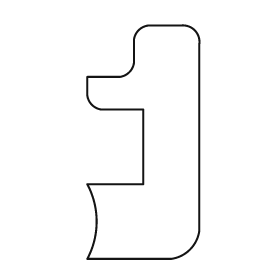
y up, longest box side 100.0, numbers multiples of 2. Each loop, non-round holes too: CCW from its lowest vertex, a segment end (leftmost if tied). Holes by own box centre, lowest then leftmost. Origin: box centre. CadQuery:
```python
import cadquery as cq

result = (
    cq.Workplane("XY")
    .moveTo(-24.0, -50.0)
    .lineTo(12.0, -50.0)
    .threePointArc((20.0, -46.0), (24.0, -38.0))
    .lineTo(24.0, 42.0)
    .threePointArc((22.0, 48.0), (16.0, 50.0))
    .lineTo(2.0, 50.0)
    .threePointArc((-2.0, 48.0), (-4.0, 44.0))
    .lineTo(-4.0, 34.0)
    .threePointArc((-6.0, 30.0), (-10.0, 28.0))
    .lineTo(-24.0, 28.0)
    .lineTo(-24.0, 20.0)
    .threePointArc((-22.0, 16.0), (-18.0, 14.0))
    .lineTo(0.0, 14.0)
    .lineTo(0.0, -18.0)
    .lineTo(-24.0, -18.0)
    .threePointArc((-20.0, -34.0), (-24.0, -50.0))
    .close()
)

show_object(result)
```